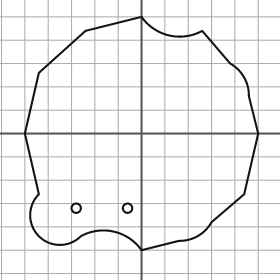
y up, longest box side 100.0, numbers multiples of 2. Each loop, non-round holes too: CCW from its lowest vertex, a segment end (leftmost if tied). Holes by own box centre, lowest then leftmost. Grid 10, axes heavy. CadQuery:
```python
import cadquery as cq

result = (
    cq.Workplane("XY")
    .moveTo(0.0, -50.0)
    .lineTo(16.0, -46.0)
    .threePointArc((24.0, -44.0), (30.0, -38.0))
    .lineTo(44.0, -26.0)
    .lineTo(50.0, 0.0)
    .lineTo(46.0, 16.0)
    .threePointArc((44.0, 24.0), (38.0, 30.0))
    .lineTo(26.0, 44.0)
    .threePointArc((12.0, 42.0), (0.0, 50.0))
    .lineTo(-24.0, 44.0)
    .lineTo(-44.0, 26.0)
    .lineTo(-50.0, 0.0)
    .lineTo(-44.0, -26.0)
    .threePointArc((-44.0, -44.0), (-26.0, -44.0))
    .threePointArc((-12.0, -42.0), (0.0, -50.0))
    .close()
    .moveTo(-28.0, -32.0)
    .circle(2.0)
    .moveTo(-6.0, -32.0)
    .circle(2.0)
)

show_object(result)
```